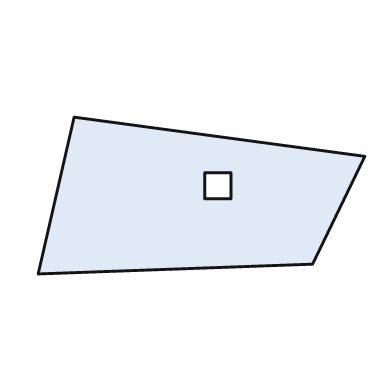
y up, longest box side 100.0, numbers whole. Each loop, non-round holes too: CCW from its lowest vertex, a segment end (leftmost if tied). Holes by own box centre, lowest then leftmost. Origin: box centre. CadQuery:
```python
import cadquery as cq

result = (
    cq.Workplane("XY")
    .moveTo(-50.0, -24.0)
    .lineTo(34.0, -21.0)
    .lineTo(50.0, 12.0)
    .lineTo(-39.0, 24.0)
    .close()
    .moveTo(1.0, -1.0)
    .lineTo(9.0, -1.0)
    .lineTo(9.0, 7.0)
    .lineTo(1.0, 7.0)
    .close()
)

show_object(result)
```